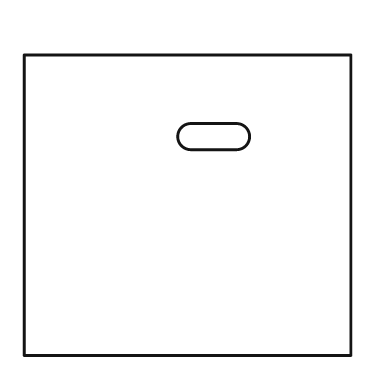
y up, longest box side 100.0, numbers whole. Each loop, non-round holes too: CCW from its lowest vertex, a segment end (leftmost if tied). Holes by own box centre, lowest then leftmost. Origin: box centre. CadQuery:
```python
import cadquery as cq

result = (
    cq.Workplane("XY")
    .moveTo(-50.0, -46.0)
    .lineTo(50.0, -46.0)
    .lineTo(50.0, 46.0)
    .lineTo(-50.0, 46.0)
    .close()
    .moveTo(1.0, 17.0)
    .lineTo(15.0, 17.0)
    .threePointArc((19.0, 21.0), (15.0, 25.0))
    .lineTo(1.0, 25.0)
    .threePointArc((-3.0, 21.0), (1.0, 17.0))
    .close()
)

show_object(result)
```